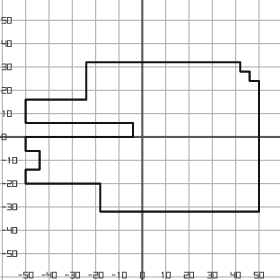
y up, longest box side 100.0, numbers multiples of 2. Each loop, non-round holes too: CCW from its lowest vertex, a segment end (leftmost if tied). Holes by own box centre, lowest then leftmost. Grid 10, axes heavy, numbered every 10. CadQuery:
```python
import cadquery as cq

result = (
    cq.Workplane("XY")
    .moveTo(-18.0, -32.0)
    .lineTo(50.0, -32.0)
    .lineTo(50.0, 24.0)
    .lineTo(46.0, 24.0)
    .lineTo(46.0, 28.0)
    .lineTo(42.0, 28.0)
    .lineTo(42.0, 32.0)
    .lineTo(-24.0, 32.0)
    .lineTo(-24.0, 16.0)
    .lineTo(-50.0, 16.0)
    .lineTo(-50.0, 6.0)
    .lineTo(-4.0, 6.0)
    .lineTo(-4.0, 0.0)
    .lineTo(-50.0, 0.0)
    .lineTo(-50.0, -6.0)
    .lineTo(-44.0, -6.0)
    .lineTo(-44.0, -14.0)
    .lineTo(-50.0, -14.0)
    .lineTo(-50.0, -20.0)
    .lineTo(-18.0, -20.0)
    .close()
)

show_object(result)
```